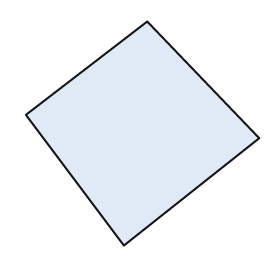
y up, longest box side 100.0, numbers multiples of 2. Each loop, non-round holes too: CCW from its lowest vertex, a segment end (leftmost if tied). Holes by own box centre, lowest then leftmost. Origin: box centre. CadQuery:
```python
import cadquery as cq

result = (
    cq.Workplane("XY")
    .moveTo(-8.0, -48.0)
    .lineTo(50.0, -2.0)
    .lineTo(2.0, 48.0)
    .lineTo(-50.0, 8.0)
    .close()
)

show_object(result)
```